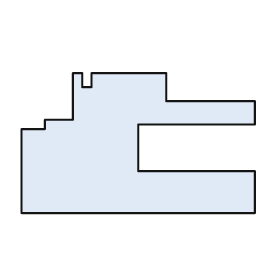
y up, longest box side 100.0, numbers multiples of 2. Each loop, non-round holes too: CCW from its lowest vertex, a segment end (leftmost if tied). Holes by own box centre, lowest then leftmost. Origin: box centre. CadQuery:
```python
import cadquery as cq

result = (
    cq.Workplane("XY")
    .moveTo(-50.0, -30.0)
    .lineTo(50.0, -30.0)
    .lineTo(50.0, -12.0)
    .lineTo(0.0, -12.0)
    .lineTo(0.0, 8.0)
    .lineTo(50.0, 8.0)
    .lineTo(50.0, 18.0)
    .lineTo(12.0, 18.0)
    .lineTo(12.0, 30.0)
    .lineTo(-20.0, 30.0)
    .lineTo(-20.0, 24.0)
    .lineTo(-24.0, 24.0)
    .lineTo(-24.0, 30.0)
    .lineTo(-28.0, 30.0)
    .lineTo(-28.0, 10.0)
    .lineTo(-40.0, 10.0)
    .lineTo(-40.0, 6.0)
    .lineTo(-50.0, 6.0)
    .close()
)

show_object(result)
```